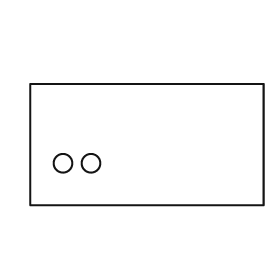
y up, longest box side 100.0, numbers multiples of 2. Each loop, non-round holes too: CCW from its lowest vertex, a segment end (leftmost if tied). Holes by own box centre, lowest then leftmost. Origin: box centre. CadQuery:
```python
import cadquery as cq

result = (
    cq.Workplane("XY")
    .moveTo(-50.0, -26.0)
    .lineTo(50.0, -26.0)
    .lineTo(50.0, 26.0)
    .lineTo(-50.0, 26.0)
    .close()
    .moveTo(-36.0, -8.0)
    .circle(4.0)
    .moveTo(-24.0, -8.0)
    .circle(4.0)
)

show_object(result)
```